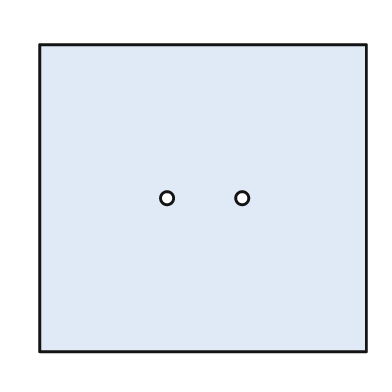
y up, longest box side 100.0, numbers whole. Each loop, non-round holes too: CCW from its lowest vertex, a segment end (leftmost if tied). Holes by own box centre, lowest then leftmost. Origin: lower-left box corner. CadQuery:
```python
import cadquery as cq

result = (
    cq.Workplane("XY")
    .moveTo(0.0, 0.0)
    .lineTo(100.0, 0.0)
    .lineTo(100.0, 94.0)
    .lineTo(0.0, 94.0)
    .close()
    .moveTo(39.0, 47.0)
    .circle(2.0)
    .moveTo(62.0, 47.0)
    .circle(2.0)
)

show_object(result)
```